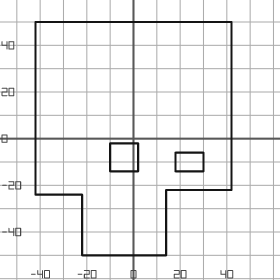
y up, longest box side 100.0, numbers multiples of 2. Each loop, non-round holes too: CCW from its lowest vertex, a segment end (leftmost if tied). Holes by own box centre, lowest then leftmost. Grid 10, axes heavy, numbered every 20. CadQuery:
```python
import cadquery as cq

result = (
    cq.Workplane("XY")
    .moveTo(-22.0, -50.0)
    .lineTo(14.0, -50.0)
    .lineTo(14.0, -22.0)
    .lineTo(42.0, -22.0)
    .lineTo(42.0, 50.0)
    .lineTo(-42.0, 50.0)
    .lineTo(-42.0, -24.0)
    .lineTo(-22.0, -24.0)
    .close()
    .moveTo(18.0, -14.0)
    .lineTo(30.0, -14.0)
    .lineTo(30.0, -6.0)
    .lineTo(18.0, -6.0)
    .close()
    .moveTo(-10.0, -14.0)
    .lineTo(2.0, -14.0)
    .lineTo(2.0, -2.0)
    .lineTo(-10.0, -2.0)
    .close()
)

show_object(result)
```